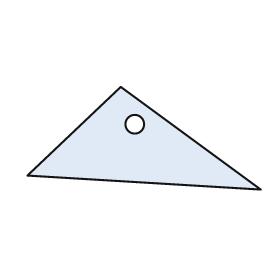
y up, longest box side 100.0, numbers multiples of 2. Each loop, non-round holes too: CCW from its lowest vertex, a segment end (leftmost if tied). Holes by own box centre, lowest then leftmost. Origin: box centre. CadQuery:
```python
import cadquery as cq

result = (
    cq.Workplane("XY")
    .moveTo(50.0, -22.0)
    .lineTo(-10.0, 22.0)
    .lineTo(-50.0, -16.0)
    .close()
    .moveTo(-4.0, 6.0)
    .circle(4.0)
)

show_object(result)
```